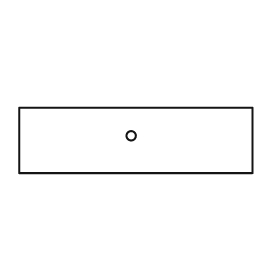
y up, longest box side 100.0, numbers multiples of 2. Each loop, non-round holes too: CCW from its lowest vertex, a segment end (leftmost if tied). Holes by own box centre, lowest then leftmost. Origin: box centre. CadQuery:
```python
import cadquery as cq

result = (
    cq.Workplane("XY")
    .moveTo(-50.0, -14.0)
    .lineTo(50.0, -14.0)
    .lineTo(50.0, 14.0)
    .lineTo(-50.0, 14.0)
    .close()
    .moveTo(-2.0, 2.0)
    .circle(2.0)
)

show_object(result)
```